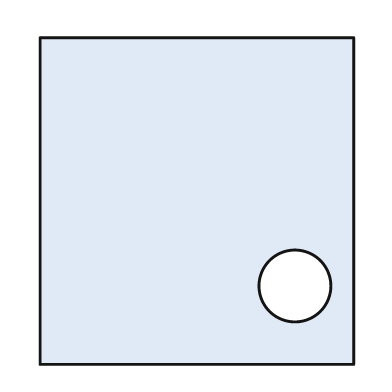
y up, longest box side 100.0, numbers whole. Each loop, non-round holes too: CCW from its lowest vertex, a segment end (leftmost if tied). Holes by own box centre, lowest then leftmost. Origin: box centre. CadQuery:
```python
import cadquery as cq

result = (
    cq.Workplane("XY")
    .moveTo(-48.0, -50.0)
    .lineTo(48.0, -50.0)
    .lineTo(48.0, 50.0)
    .lineTo(-48.0, 50.0)
    .close()
    .moveTo(30.0, -26.0)
    .circle(11.0)
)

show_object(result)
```